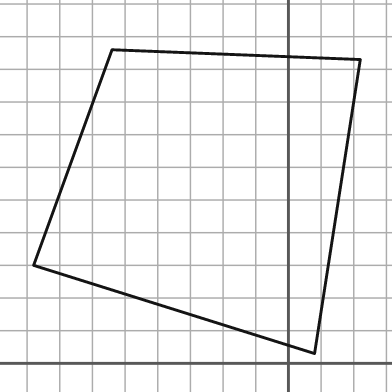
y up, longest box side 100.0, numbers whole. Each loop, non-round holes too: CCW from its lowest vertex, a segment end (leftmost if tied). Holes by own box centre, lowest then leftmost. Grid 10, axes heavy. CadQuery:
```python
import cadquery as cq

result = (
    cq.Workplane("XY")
    .moveTo(8.0, 3.0)
    .lineTo(22.0, 93.0)
    .lineTo(-54.0, 96.0)
    .lineTo(-78.0, 30.0)
    .close()
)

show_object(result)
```